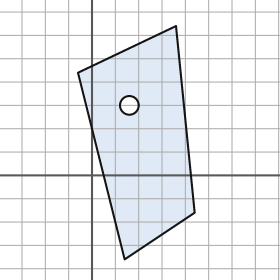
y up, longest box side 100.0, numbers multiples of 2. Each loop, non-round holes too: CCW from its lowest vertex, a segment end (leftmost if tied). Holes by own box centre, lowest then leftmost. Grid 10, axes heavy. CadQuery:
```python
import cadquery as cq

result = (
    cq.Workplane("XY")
    .moveTo(14.0, -36.0)
    .lineTo(44.0, -16.0)
    .lineTo(36.0, 64.0)
    .lineTo(-6.0, 44.0)
    .close()
    .moveTo(16.0, 30.0)
    .circle(4.0)
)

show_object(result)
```